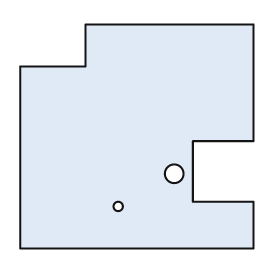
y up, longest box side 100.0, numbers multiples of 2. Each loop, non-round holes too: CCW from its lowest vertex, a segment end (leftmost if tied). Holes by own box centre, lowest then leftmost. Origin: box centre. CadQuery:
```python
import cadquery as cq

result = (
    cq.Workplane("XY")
    .moveTo(-50.0, -48.0)
    .lineTo(50.0, -48.0)
    .lineTo(50.0, -28.0)
    .lineTo(24.0, -28.0)
    .lineTo(24.0, -2.0)
    .lineTo(50.0, -2.0)
    .lineTo(50.0, 48.0)
    .lineTo(-22.0, 48.0)
    .lineTo(-22.0, 30.0)
    .lineTo(-50.0, 30.0)
    .close()
    .moveTo(-8.0, -30.0)
    .circle(2.0)
    .moveTo(16.0, -16.0)
    .circle(4.0)
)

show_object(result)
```